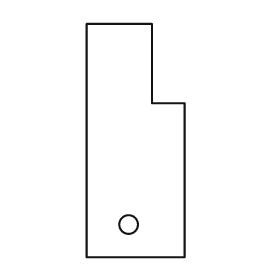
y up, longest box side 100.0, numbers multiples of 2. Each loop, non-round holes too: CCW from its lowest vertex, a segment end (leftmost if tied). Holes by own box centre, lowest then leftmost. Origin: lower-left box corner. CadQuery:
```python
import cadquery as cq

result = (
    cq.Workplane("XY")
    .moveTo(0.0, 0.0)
    .lineTo(42.0, 0.0)
    .lineTo(42.0, 66.0)
    .lineTo(28.0, 66.0)
    .lineTo(28.0, 100.0)
    .lineTo(0.0, 100.0)
    .close()
    .moveTo(18.0, 14.0)
    .circle(4.0)
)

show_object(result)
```